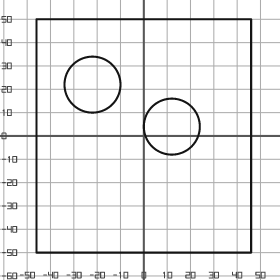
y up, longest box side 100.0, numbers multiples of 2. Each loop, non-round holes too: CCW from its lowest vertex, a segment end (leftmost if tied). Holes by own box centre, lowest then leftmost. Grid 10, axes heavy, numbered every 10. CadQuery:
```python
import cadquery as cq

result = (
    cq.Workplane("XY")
    .moveTo(-46.0, -50.0)
    .lineTo(46.0, -50.0)
    .lineTo(46.0, 50.0)
    .lineTo(-46.0, 50.0)
    .close()
    .moveTo(12.0, 4.0)
    .circle(12.0)
    .moveTo(-22.0, 22.0)
    .circle(12.0)
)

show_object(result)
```